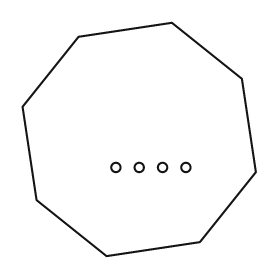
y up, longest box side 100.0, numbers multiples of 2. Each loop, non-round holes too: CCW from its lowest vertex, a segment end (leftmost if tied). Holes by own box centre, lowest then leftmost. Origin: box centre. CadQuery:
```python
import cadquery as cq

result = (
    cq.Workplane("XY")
    .moveTo(-14.0, -50.0)
    .lineTo(26.0, -44.0)
    .lineTo(50.0, -14.0)
    .lineTo(44.0, 26.0)
    .lineTo(14.0, 50.0)
    .lineTo(-26.0, 44.0)
    .lineTo(-50.0, 14.0)
    .lineTo(-44.0, -26.0)
    .close()
    .moveTo(-10.0, -12.0)
    .circle(2.0)
    .moveTo(0.0, -12.0)
    .circle(2.0)
    .moveTo(10.0, -12.0)
    .circle(2.0)
    .moveTo(20.0, -12.0)
    .circle(2.0)
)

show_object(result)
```